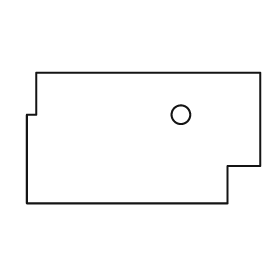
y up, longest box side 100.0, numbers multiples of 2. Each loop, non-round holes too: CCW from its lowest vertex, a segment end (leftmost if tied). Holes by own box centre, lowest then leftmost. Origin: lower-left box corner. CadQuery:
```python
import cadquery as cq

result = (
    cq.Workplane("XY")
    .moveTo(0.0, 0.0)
    .lineTo(86.0, 0.0)
    .lineTo(86.0, 16.0)
    .lineTo(100.0, 16.0)
    .lineTo(100.0, 56.0)
    .lineTo(4.0, 56.0)
    .lineTo(4.0, 38.0)
    .lineTo(0.0, 38.0)
    .close()
    .moveTo(66.0, 38.0)
    .circle(4.0)
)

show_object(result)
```